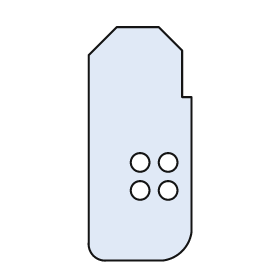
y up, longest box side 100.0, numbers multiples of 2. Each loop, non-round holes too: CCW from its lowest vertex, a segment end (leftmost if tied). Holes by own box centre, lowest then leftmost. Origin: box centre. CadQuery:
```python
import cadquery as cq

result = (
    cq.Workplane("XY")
    .moveTo(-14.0, -50.0)
    .lineTo(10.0, -50.0)
    .threePointArc((18.0, -46.0), (22.0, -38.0))
    .lineTo(22.0, 20.0)
    .lineTo(18.0, 20.0)
    .lineTo(18.0, 40.0)
    .lineTo(8.0, 50.0)
    .lineTo(-10.0, 50.0)
    .lineTo(-22.0, 38.0)
    .lineTo(-22.0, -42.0)
    .threePointArc((-20.0, -48.0), (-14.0, -50.0))
    .close()
    .moveTo(0.0, -20.0)
    .circle(4.0)
    .moveTo(12.0, -20.0)
    .circle(4.0)
    .moveTo(0.0, -8.0)
    .circle(4.0)
    .moveTo(12.0, -8.0)
    .circle(4.0)
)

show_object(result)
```